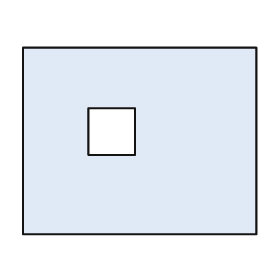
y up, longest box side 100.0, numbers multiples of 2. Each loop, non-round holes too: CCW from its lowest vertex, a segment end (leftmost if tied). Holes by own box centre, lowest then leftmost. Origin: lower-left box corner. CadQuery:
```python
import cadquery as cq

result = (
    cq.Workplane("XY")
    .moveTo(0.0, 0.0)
    .lineTo(100.0, 0.0)
    .lineTo(100.0, 80.0)
    .lineTo(0.0, 80.0)
    .close()
    .moveTo(28.0, 34.0)
    .lineTo(48.0, 34.0)
    .lineTo(48.0, 54.0)
    .lineTo(28.0, 54.0)
    .close()
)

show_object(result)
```